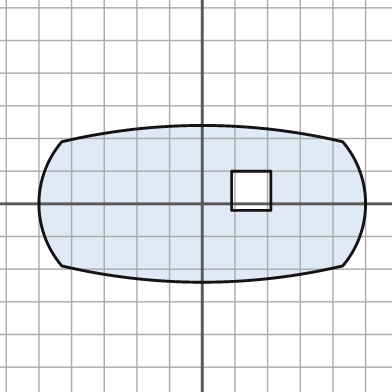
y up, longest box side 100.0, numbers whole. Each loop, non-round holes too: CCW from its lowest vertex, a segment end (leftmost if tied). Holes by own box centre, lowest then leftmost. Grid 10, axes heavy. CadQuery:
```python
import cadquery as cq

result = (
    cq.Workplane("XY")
    .moveTo(-43.0, -19.0)
    .threePointArc((0.0, -24.0), (43.0, -19.0))
    .threePointArc((50.0, 0.0), (43.0, 19.0))
    .threePointArc((0.0, 24.0), (-43.0, 19.0))
    .threePointArc((-50.0, 0.0), (-43.0, -19.0))
    .close()
    .moveTo(9.0, -2.0)
    .lineTo(21.0, -2.0)
    .lineTo(21.0, 10.0)
    .lineTo(9.0, 10.0)
    .close()
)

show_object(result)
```